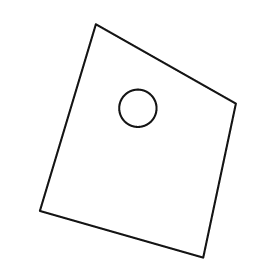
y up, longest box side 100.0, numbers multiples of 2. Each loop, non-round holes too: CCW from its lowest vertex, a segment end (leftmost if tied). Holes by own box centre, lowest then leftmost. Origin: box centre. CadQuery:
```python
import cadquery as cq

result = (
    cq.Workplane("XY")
    .moveTo(28.0, -50.0)
    .lineTo(42.0, 16.0)
    .lineTo(-18.0, 50.0)
    .lineTo(-42.0, -30.0)
    .close()
    .moveTo(0.0, 14.0)
    .circle(8.0)
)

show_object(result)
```